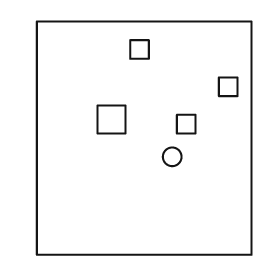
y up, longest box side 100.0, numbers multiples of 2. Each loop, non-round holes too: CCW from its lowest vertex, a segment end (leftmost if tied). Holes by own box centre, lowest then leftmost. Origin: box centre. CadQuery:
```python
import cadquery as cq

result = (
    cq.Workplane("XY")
    .moveTo(-46.0, -50.0)
    .lineTo(46.0, -50.0)
    .lineTo(46.0, 50.0)
    .lineTo(-46.0, 50.0)
    .close()
    .moveTo(12.0, -8.0)
    .circle(4.0)
    .moveTo(14.0, 2.0)
    .lineTo(22.0, 2.0)
    .lineTo(22.0, 10.0)
    .lineTo(14.0, 10.0)
    .close()
    .moveTo(-20.0, 2.0)
    .lineTo(-8.0, 2.0)
    .lineTo(-8.0, 14.0)
    .lineTo(-20.0, 14.0)
    .close()
    .moveTo(32.0, 18.0)
    .lineTo(40.0, 18.0)
    .lineTo(40.0, 26.0)
    .lineTo(32.0, 26.0)
    .close()
    .moveTo(-6.0, 34.0)
    .lineTo(2.0, 34.0)
    .lineTo(2.0, 42.0)
    .lineTo(-6.0, 42.0)
    .close()
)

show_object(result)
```